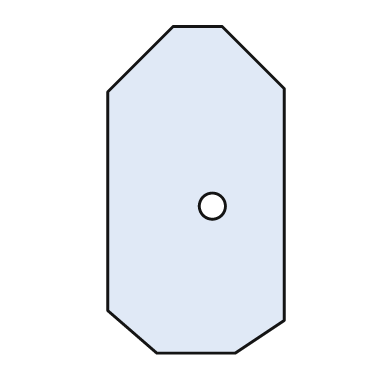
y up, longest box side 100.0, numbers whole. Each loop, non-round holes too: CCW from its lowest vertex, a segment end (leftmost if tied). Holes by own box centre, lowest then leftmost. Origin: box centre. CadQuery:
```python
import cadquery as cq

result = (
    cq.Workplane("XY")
    .moveTo(-12.0, -50.0)
    .lineTo(12.0, -50.0)
    .lineTo(27.0, -40.0)
    .lineTo(27.0, 31.0)
    .lineTo(8.0, 50.0)
    .lineTo(-7.0, 50.0)
    .lineTo(-27.0, 30.0)
    .lineTo(-27.0, -37.0)
    .close()
    .moveTo(5.0, -5.0)
    .circle(4.0)
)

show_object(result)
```